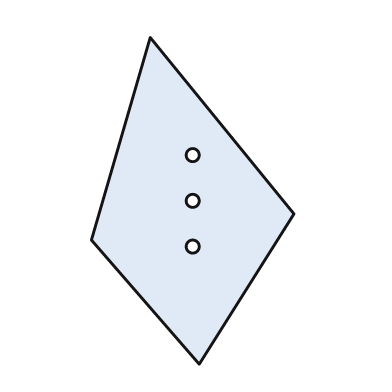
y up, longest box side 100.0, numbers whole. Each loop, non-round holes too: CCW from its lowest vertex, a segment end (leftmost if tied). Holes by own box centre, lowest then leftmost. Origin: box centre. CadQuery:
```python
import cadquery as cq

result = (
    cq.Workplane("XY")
    .moveTo(2.0, -50.0)
    .lineTo(31.0, -4.0)
    .lineTo(-13.0, 50.0)
    .lineTo(-31.0, -12.0)
    .close()
    .moveTo(0.0, -14.0)
    .circle(2.0)
    .moveTo(0.0, 0.0)
    .circle(2.0)
    .moveTo(0.0, 14.0)
    .circle(2.0)
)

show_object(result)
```